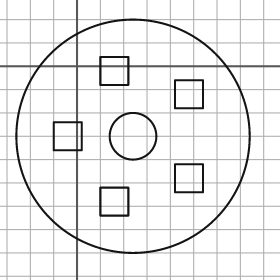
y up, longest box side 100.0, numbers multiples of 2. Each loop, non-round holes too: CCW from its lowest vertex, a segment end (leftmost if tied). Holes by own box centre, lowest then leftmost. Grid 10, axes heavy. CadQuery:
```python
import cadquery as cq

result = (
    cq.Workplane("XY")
    .moveTo(24.0, -30.0)
    .circle(50.0)
    .moveTo(10.0, -64.0)
    .lineTo(22.0, -64.0)
    .lineTo(22.0, -52.0)
    .lineTo(10.0, -52.0)
    .close()
    .moveTo(42.0, -54.0)
    .lineTo(54.0, -54.0)
    .lineTo(54.0, -42.0)
    .lineTo(42.0, -42.0)
    .close()
    .moveTo(-10.0, -36.0)
    .lineTo(2.0, -36.0)
    .lineTo(2.0, -24.0)
    .lineTo(-10.0, -24.0)
    .close()
    .moveTo(24.0, -30.0)
    .circle(10.0)
    .moveTo(42.0, -18.0)
    .lineTo(54.0, -18.0)
    .lineTo(54.0, -6.0)
    .lineTo(42.0, -6.0)
    .close()
    .moveTo(10.0, -8.0)
    .lineTo(22.0, -8.0)
    .lineTo(22.0, 4.0)
    .lineTo(10.0, 4.0)
    .close()
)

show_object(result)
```